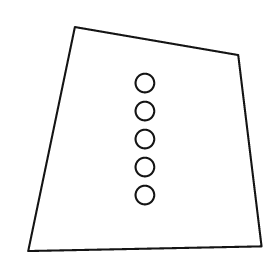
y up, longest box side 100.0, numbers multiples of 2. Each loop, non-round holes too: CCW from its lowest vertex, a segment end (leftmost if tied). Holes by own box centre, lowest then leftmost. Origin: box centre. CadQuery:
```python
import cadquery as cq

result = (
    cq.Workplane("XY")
    .moveTo(-50.0, -48.0)
    .lineTo(50.0, -46.0)
    .lineTo(40.0, 36.0)
    .lineTo(-30.0, 48.0)
    .close()
    .moveTo(0.0, -24.0)
    .circle(4.0)
    .moveTo(0.0, -12.0)
    .circle(4.0)
    .moveTo(0.0, 0.0)
    .circle(4.0)
    .moveTo(0.0, 12.0)
    .circle(4.0)
    .moveTo(0.0, 24.0)
    .circle(4.0)
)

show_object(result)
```